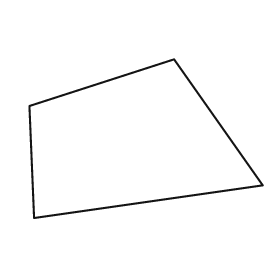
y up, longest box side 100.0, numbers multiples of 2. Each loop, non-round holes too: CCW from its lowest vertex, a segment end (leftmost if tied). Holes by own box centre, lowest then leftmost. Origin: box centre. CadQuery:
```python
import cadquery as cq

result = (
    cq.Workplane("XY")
    .moveTo(-48.0, -34.0)
    .lineTo(50.0, -20.0)
    .lineTo(12.0, 34.0)
    .lineTo(-50.0, 14.0)
    .close()
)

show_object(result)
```